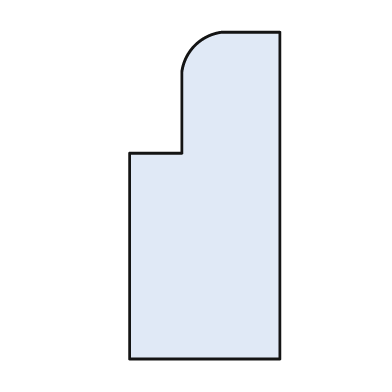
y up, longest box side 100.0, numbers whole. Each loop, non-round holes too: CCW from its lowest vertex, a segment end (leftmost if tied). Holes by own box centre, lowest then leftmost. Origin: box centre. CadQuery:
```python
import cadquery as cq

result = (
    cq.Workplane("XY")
    .moveTo(-23.0, -50.0)
    .lineTo(23.0, -50.0)
    .lineTo(23.0, 50.0)
    .lineTo(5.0, 50.0)
    .threePointArc((-3.0, 46.0), (-7.0, 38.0))
    .lineTo(-7.0, 13.0)
    .lineTo(-23.0, 13.0)
    .close()
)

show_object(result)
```